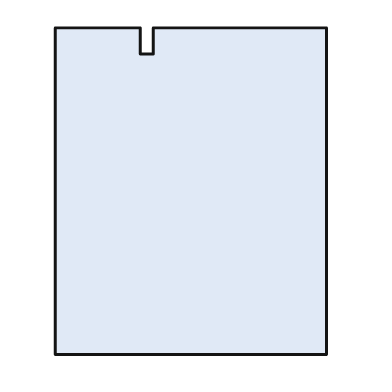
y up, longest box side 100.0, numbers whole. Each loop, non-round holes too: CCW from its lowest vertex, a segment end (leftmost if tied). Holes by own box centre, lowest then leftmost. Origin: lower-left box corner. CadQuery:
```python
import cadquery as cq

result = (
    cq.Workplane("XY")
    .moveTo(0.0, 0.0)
    .lineTo(83.0, 0.0)
    .lineTo(83.0, 100.0)
    .lineTo(30.0, 100.0)
    .lineTo(30.0, 92.0)
    .lineTo(26.0, 92.0)
    .lineTo(26.0, 100.0)
    .lineTo(0.0, 100.0)
    .close()
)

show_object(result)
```